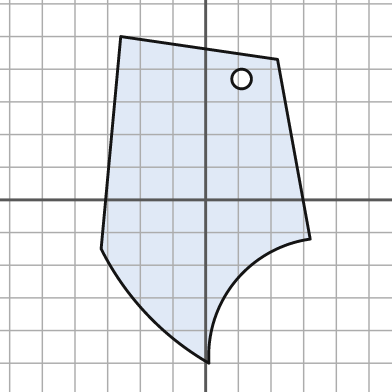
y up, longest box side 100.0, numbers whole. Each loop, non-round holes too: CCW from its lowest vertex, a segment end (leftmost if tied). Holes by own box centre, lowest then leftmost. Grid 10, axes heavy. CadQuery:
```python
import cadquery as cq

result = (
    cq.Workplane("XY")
    .moveTo(1.0, -50.0)
    .threePointArc((9.0, -25.0), (32.0, -12.0))
    .lineTo(22.0, 43.0)
    .lineTo(-26.0, 50.0)
    .lineTo(-32.0, -15.0)
    .threePointArc((-18.0, -35.0), (1.0, -50.0))
    .close()
    .moveTo(11.0, 37.0)
    .circle(3.0)
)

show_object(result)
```